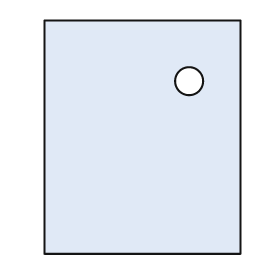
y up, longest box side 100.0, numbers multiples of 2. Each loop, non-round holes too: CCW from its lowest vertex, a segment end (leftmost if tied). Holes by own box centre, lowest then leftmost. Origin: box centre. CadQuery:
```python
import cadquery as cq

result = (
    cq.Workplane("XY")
    .moveTo(-42.0, -50.0)
    .lineTo(42.0, -50.0)
    .lineTo(42.0, 50.0)
    .lineTo(-42.0, 50.0)
    .close()
    .moveTo(20.0, 24.0)
    .circle(6.0)
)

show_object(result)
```